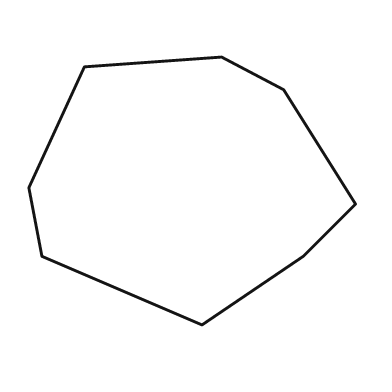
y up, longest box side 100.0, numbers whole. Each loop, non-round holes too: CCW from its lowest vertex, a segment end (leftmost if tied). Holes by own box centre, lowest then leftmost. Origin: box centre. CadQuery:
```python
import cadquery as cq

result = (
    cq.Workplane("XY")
    .moveTo(3.0, -41.0)
    .lineTo(34.0, -20.0)
    .lineTo(50.0, -4.0)
    .lineTo(28.0, 31.0)
    .lineTo(9.0, 41.0)
    .lineTo(-33.0, 38.0)
    .lineTo(-50.0, 1.0)
    .lineTo(-46.0, -20.0)
    .close()
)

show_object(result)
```